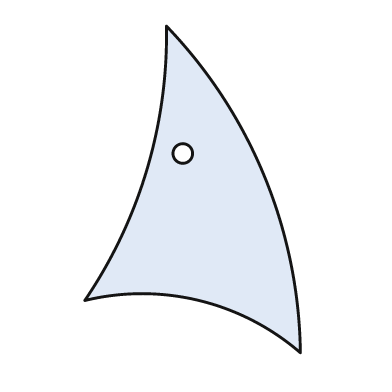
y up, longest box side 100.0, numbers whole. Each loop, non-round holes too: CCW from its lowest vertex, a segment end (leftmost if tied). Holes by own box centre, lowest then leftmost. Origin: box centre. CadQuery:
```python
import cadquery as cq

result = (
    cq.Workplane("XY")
    .moveTo(33.0, -50.0)
    .threePointArc((22.0, 4.0), (-8.0, 50.0))
    .threePointArc((-14.0, 6.0), (-33.0, -34.0))
    .threePointArc((2.0, -34.0), (33.0, -50.0))
    .close()
    .moveTo(-3.0, 11.0)
    .circle(3.0)
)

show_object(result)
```